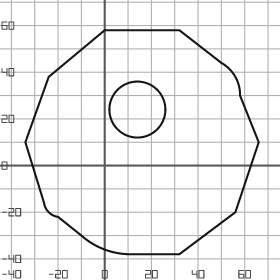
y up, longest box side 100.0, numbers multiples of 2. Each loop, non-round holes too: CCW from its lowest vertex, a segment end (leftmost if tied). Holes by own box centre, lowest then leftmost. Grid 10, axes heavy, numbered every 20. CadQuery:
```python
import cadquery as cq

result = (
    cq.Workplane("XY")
    .moveTo(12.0, -38.0)
    .lineTo(32.0, -38.0)
    .lineTo(56.0, -20.0)
    .lineTo(66.0, 10.0)
    .lineTo(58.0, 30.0)
    .threePointArc((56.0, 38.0), (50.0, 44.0))
    .lineTo(32.0, 58.0)
    .lineTo(0.0, 58.0)
    .lineTo(-24.0, 38.0)
    .lineTo(-34.0, 10.0)
    .lineTo(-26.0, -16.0)
    .threePointArc((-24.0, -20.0), (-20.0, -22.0))
    .lineTo(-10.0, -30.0)
    .threePointArc((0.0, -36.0), (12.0, -38.0))
    .close()
    .moveTo(14.0, 24.0)
    .circle(12.0)
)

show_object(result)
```